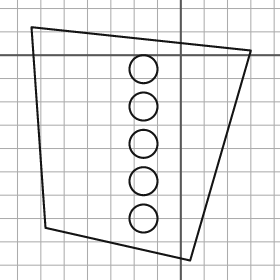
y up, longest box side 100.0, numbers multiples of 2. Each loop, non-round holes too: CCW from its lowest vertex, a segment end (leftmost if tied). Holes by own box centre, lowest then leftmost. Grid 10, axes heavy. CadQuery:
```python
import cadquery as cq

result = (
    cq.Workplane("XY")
    .moveTo(4.0, -88.0)
    .lineTo(30.0, 2.0)
    .lineTo(-64.0, 12.0)
    .lineTo(-58.0, -74.0)
    .close()
    .moveTo(-16.0, -70.0)
    .circle(6.0)
    .moveTo(-16.0, -54.0)
    .circle(6.0)
    .moveTo(-16.0, -38.0)
    .circle(6.0)
    .moveTo(-16.0, -22.0)
    .circle(6.0)
    .moveTo(-16.0, -6.0)
    .circle(6.0)
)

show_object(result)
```